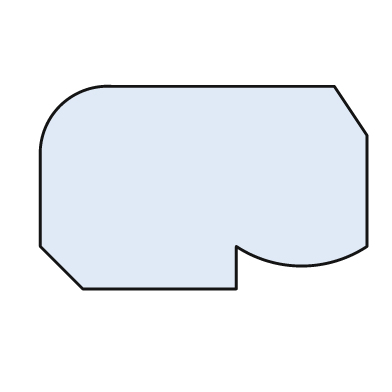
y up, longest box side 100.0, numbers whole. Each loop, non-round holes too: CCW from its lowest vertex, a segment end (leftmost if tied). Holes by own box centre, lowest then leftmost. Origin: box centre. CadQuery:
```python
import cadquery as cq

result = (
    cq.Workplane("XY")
    .moveTo(-37.0, -31.0)
    .lineTo(10.0, -31.0)
    .lineTo(10.0, -18.0)
    .threePointArc((30.0, -24.0), (50.0, -18.0))
    .lineTo(50.0, 16.0)
    .lineTo(40.0, 31.0)
    .lineTo(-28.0, 31.0)
    .threePointArc((-44.0, 25.0), (-50.0, 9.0))
    .lineTo(-50.0, -18.0)
    .close()
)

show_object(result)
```